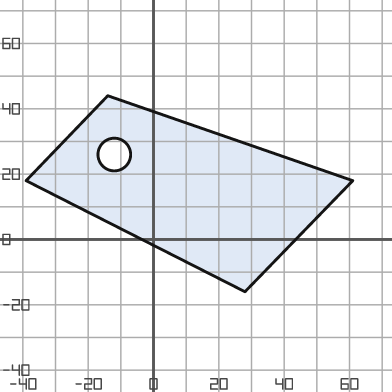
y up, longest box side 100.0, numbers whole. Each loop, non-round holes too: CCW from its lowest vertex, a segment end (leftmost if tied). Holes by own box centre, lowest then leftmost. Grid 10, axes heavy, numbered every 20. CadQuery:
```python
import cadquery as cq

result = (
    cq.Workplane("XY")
    .moveTo(28.0, -16.0)
    .lineTo(61.0, 18.0)
    .lineTo(-14.0, 44.0)
    .lineTo(-39.0, 18.0)
    .close()
    .moveTo(-12.0, 26.0)
    .circle(5.0)
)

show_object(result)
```